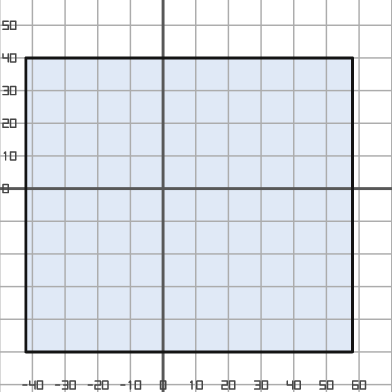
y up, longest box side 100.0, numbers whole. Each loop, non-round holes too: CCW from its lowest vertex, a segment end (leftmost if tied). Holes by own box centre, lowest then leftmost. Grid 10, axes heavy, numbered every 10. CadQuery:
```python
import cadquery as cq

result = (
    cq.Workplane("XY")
    .moveTo(-42.0, -50.0)
    .lineTo(58.0, -50.0)
    .lineTo(58.0, 40.0)
    .lineTo(-42.0, 40.0)
    .close()
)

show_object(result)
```